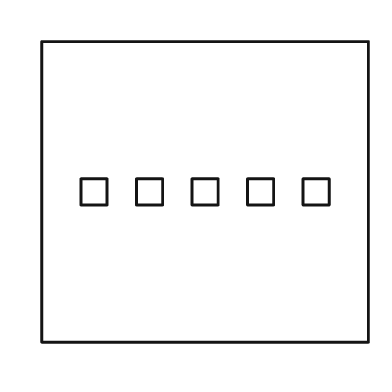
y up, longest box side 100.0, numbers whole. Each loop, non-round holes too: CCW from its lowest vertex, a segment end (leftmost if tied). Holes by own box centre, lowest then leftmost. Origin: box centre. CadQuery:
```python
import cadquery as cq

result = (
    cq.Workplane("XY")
    .moveTo(-50.0, -46.0)
    .lineTo(50.0, -46.0)
    .lineTo(50.0, 46.0)
    .lineTo(-50.0, 46.0)
    .close()
    .moveTo(-38.0, -4.0)
    .lineTo(-30.0, -4.0)
    .lineTo(-30.0, 4.0)
    .lineTo(-38.0, 4.0)
    .close()
    .moveTo(-21.0, -4.0)
    .lineTo(-13.0, -4.0)
    .lineTo(-13.0, 4.0)
    .lineTo(-21.0, 4.0)
    .close()
    .moveTo(-4.0, -4.0)
    .lineTo(4.0, -4.0)
    .lineTo(4.0, 4.0)
    .lineTo(-4.0, 4.0)
    .close()
    .moveTo(13.0, -4.0)
    .lineTo(21.0, -4.0)
    .lineTo(21.0, 4.0)
    .lineTo(13.0, 4.0)
    .close()
    .moveTo(30.0, -4.0)
    .lineTo(38.0, -4.0)
    .lineTo(38.0, 4.0)
    .lineTo(30.0, 4.0)
    .close()
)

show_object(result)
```